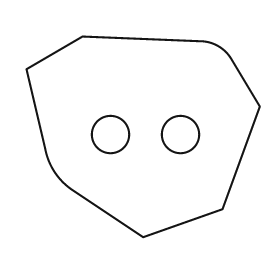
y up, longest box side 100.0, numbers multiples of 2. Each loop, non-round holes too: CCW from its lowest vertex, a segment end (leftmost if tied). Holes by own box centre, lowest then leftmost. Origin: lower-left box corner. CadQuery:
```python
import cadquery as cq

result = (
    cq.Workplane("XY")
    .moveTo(50.0, 0.0)
    .lineTo(84.0, 12.0)
    .lineTo(100.0, 56.0)
    .lineTo(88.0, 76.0)
    .threePointArc((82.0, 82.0), (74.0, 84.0))
    .lineTo(24.0, 86.0)
    .lineTo(0.0, 72.0)
    .lineTo(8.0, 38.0)
    .threePointArc((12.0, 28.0), (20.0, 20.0))
    .close()
    .moveTo(36.0, 44.0)
    .circle(8.0)
    .moveTo(66.0, 44.0)
    .circle(8.0)
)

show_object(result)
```